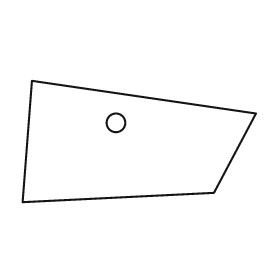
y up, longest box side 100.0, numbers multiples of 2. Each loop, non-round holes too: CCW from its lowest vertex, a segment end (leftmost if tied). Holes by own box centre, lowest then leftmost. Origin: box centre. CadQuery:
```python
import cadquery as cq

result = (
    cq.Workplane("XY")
    .moveTo(-50.0, -26.0)
    .lineTo(32.0, -22.0)
    .lineTo(50.0, 12.0)
    .lineTo(-46.0, 26.0)
    .close()
    .moveTo(-10.0, 8.0)
    .circle(4.0)
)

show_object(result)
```